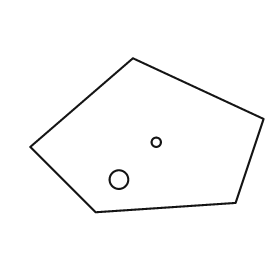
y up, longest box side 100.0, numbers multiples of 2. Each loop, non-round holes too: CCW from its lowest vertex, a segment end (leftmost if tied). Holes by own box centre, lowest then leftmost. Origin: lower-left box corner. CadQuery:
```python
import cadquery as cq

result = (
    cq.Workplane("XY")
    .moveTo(28.0, 0.0)
    .lineTo(88.0, 4.0)
    .lineTo(100.0, 40.0)
    .lineTo(44.0, 66.0)
    .lineTo(0.0, 28.0)
    .close()
    .moveTo(38.0, 14.0)
    .circle(4.0)
    .moveTo(54.0, 30.0)
    .circle(2.0)
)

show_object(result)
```